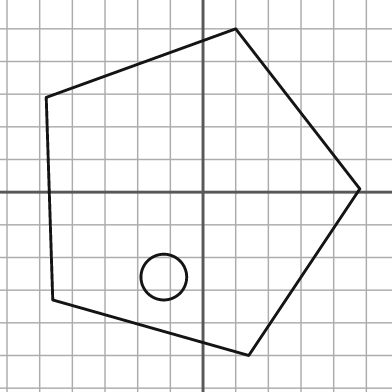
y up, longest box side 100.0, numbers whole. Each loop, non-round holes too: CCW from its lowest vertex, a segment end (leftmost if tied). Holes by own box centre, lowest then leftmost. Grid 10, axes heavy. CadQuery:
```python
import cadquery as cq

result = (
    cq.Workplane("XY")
    .moveTo(14.0, -50.0)
    .lineTo(48.0, 1.0)
    .lineTo(10.0, 50.0)
    .lineTo(-48.0, 29.0)
    .lineTo(-46.0, -33.0)
    .close()
    .moveTo(-12.0, -26.0)
    .circle(7.0)
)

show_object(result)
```